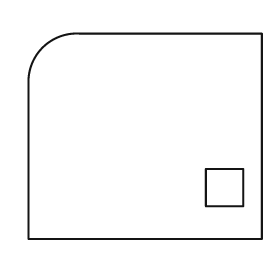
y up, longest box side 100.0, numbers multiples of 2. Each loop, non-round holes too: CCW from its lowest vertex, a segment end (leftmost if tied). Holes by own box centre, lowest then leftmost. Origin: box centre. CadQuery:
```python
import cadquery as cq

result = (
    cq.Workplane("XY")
    .moveTo(-50.0, -44.0)
    .lineTo(50.0, -44.0)
    .lineTo(50.0, 44.0)
    .lineTo(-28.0, 44.0)
    .threePointArc((-44.0, 38.0), (-50.0, 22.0))
    .close()
    .moveTo(26.0, -30.0)
    .lineTo(42.0, -30.0)
    .lineTo(42.0, -14.0)
    .lineTo(26.0, -14.0)
    .close()
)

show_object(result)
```